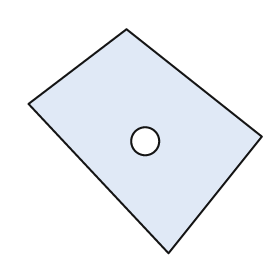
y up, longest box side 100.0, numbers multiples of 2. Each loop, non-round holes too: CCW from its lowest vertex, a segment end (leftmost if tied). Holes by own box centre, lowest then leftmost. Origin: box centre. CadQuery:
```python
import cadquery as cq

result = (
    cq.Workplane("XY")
    .moveTo(10.0, -48.0)
    .lineTo(50.0, 2.0)
    .lineTo(-8.0, 48.0)
    .lineTo(-50.0, 16.0)
    .close()
    .moveTo(0.0, 0.0)
    .circle(6.0)
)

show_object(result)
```